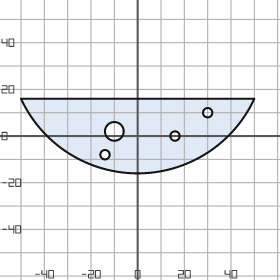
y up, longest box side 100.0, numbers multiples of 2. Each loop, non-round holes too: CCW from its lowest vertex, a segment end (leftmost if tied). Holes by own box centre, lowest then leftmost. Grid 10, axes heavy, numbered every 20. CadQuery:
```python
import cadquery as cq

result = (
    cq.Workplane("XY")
    .moveTo(-50.0, 16.0)
    .threePointArc((0.0, -16.0), (50.0, 16.0))
    .close()
    .moveTo(-14.0, -8.0)
    .circle(2.0)
    .moveTo(16.0, 0.0)
    .circle(2.0)
    .moveTo(-10.0, 2.0)
    .circle(4.0)
    .moveTo(30.0, 10.0)
    .circle(2.0)
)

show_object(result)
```